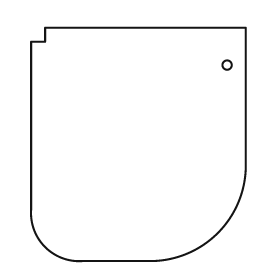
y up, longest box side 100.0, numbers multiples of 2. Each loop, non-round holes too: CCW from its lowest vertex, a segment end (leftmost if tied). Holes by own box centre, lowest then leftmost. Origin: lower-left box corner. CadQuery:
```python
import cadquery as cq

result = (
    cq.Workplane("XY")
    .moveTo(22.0, 0.0)
    .lineTo(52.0, 0.0)
    .threePointArc((80.0, 12.0), (92.0, 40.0))
    .lineTo(92.0, 100.0)
    .lineTo(6.0, 100.0)
    .lineTo(6.0, 94.0)
    .lineTo(0.0, 94.0)
    .lineTo(0.0, 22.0)
    .threePointArc((6.0, 6.0), (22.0, 0.0))
    .close()
    .moveTo(84.0, 84.0)
    .circle(2.0)
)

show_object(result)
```